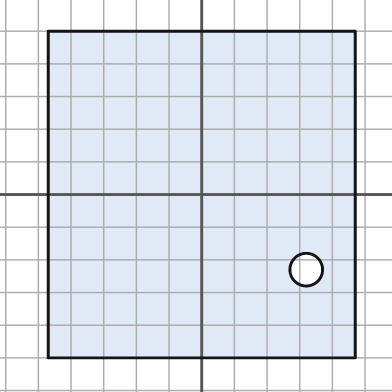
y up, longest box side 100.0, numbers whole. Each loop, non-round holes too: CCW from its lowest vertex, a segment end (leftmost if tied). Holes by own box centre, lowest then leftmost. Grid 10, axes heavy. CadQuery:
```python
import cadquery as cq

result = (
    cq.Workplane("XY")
    .moveTo(-47.0, -50.0)
    .lineTo(47.0, -50.0)
    .lineTo(47.0, 50.0)
    .lineTo(-47.0, 50.0)
    .close()
    .moveTo(32.0, -23.0)
    .circle(5.0)
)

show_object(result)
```